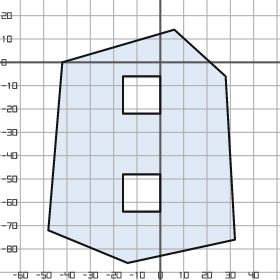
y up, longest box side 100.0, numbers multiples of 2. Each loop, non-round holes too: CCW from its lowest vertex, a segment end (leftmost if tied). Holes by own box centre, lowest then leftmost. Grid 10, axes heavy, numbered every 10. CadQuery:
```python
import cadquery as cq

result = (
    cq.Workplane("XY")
    .moveTo(-14.0, -86.0)
    .lineTo(32.0, -76.0)
    .lineTo(28.0, -6.0)
    .lineTo(6.0, 14.0)
    .lineTo(-42.0, 0.0)
    .lineTo(-48.0, -72.0)
    .close()
    .moveTo(-16.0, -64.0)
    .lineTo(0.0, -64.0)
    .lineTo(0.0, -48.0)
    .lineTo(-16.0, -48.0)
    .close()
    .moveTo(-16.0, -22.0)
    .lineTo(0.0, -22.0)
    .lineTo(0.0, -6.0)
    .lineTo(-16.0, -6.0)
    .close()
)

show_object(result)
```